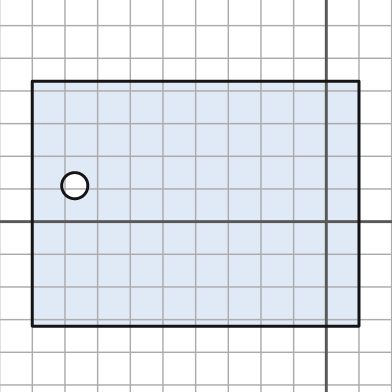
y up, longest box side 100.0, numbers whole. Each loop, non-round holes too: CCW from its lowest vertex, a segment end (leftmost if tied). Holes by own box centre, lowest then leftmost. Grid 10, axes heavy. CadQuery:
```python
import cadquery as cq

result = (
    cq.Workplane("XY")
    .moveTo(-90.0, -32.0)
    .lineTo(10.0, -32.0)
    .lineTo(10.0, 43.0)
    .lineTo(-90.0, 43.0)
    .close()
    .moveTo(-77.0, 11.0)
    .circle(4.0)
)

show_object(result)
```